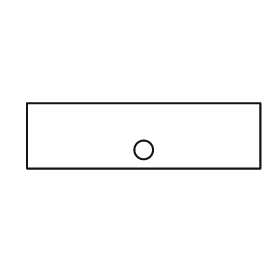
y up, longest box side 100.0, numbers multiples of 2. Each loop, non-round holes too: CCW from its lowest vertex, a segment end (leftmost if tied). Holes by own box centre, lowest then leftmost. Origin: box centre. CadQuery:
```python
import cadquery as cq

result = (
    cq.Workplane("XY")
    .moveTo(-50.0, -14.0)
    .lineTo(50.0, -14.0)
    .lineTo(50.0, 14.0)
    .lineTo(-50.0, 14.0)
    .close()
    .moveTo(0.0, -6.0)
    .circle(4.0)
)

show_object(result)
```